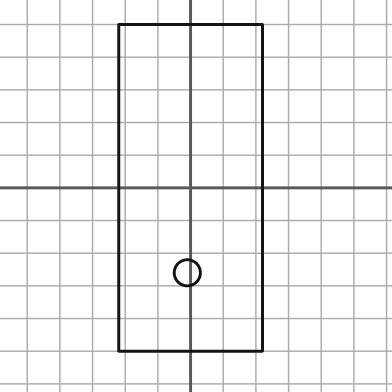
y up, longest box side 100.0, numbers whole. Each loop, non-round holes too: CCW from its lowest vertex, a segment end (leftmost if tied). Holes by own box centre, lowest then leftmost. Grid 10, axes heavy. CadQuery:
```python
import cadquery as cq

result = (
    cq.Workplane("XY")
    .moveTo(-22.0, -50.0)
    .lineTo(22.0, -50.0)
    .lineTo(22.0, 50.0)
    .lineTo(-22.0, 50.0)
    .close()
    .moveTo(-1.0, -26.0)
    .circle(4.0)
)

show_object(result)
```